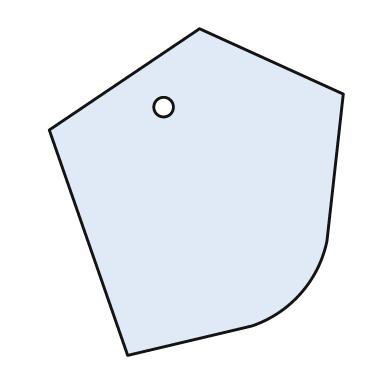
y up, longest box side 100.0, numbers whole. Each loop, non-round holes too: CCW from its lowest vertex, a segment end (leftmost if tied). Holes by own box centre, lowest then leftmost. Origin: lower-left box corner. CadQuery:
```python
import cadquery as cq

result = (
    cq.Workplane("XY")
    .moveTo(24.0, 0.0)
    .lineTo(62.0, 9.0)
    .threePointArc((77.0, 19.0), (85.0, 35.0))
    .lineTo(90.0, 80.0)
    .lineTo(46.0, 100.0)
    .lineTo(0.0, 69.0)
    .close()
    .moveTo(35.0, 76.0)
    .circle(3.0)
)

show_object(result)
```